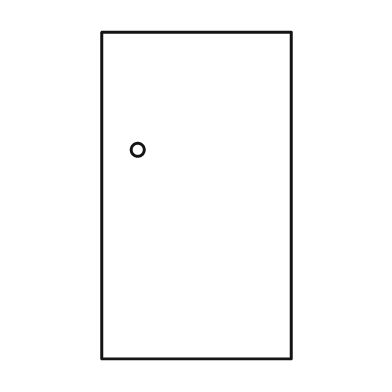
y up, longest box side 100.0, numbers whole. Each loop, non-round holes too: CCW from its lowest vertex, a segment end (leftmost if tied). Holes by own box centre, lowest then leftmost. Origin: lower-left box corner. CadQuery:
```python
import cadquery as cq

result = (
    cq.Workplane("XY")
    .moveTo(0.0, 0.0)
    .lineTo(58.0, 0.0)
    .lineTo(58.0, 100.0)
    .lineTo(0.0, 100.0)
    .close()
    .moveTo(11.0, 64.0)
    .circle(2.0)
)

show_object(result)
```